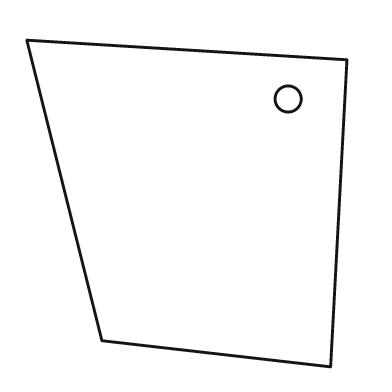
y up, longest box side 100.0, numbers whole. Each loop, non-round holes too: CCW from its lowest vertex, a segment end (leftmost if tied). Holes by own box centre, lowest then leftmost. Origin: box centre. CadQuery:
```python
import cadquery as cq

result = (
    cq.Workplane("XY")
    .moveTo(44.0, -50.0)
    .lineTo(49.0, 44.0)
    .lineTo(-49.0, 50.0)
    .lineTo(-26.0, -42.0)
    .close()
    .moveTo(31.0, 32.0)
    .circle(4.0)
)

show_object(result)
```